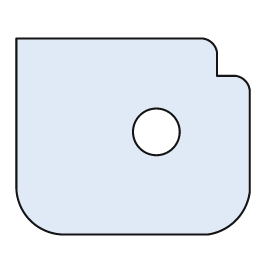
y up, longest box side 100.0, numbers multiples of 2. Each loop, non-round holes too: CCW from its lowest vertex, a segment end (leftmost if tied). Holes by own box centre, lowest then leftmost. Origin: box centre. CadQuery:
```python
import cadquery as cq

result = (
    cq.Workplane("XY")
    .moveTo(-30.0, -42.0)
    .lineTo(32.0, -42.0)
    .threePointArc((44.0, -36.0), (50.0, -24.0))
    .lineTo(50.0, 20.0)
    .threePointArc((48.0, 24.0), (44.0, 26.0))
    .lineTo(36.0, 26.0)
    .lineTo(36.0, 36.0)
    .threePointArc((34.0, 40.0), (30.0, 42.0))
    .lineTo(-50.0, 42.0)
    .lineTo(-50.0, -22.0)
    .threePointArc((-44.0, -36.0), (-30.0, -42.0))
    .close()
    .moveTo(10.0, 2.0)
    .circle(10.0)
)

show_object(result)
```